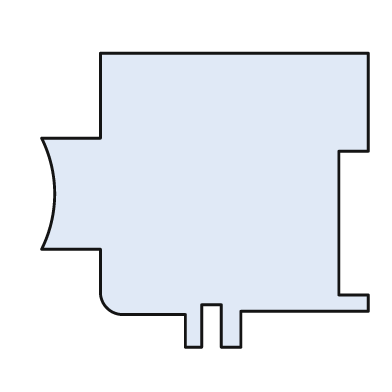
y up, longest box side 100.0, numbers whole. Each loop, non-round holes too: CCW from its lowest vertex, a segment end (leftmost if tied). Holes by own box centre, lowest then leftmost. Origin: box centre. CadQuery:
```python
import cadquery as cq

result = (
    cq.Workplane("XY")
    .moveTo(-6.0, -45.0)
    .lineTo(-1.0, -45.0)
    .lineTo(-1.0, -32.0)
    .lineTo(5.0, -32.0)
    .lineTo(5.0, -45.0)
    .lineTo(11.0, -45.0)
    .lineTo(11.0, -34.0)
    .lineTo(50.0, -34.0)
    .lineTo(50.0, -29.0)
    .lineTo(41.0, -29.0)
    .lineTo(41.0, 15.0)
    .lineTo(50.0, 15.0)
    .lineTo(50.0, 45.0)
    .lineTo(-32.0, 45.0)
    .lineTo(-32.0, 19.0)
    .lineTo(-50.0, 19.0)
    .threePointArc((-46.0, 2.0), (-50.0, -15.0))
    .lineTo(-32.0, -15.0)
    .lineTo(-32.0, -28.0)
    .threePointArc((-30.0, -33.0), (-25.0, -35.0))
    .lineTo(-6.0, -35.0)
    .close()
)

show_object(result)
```